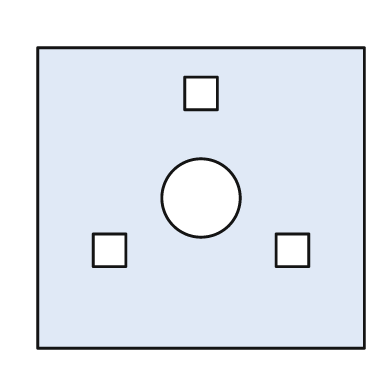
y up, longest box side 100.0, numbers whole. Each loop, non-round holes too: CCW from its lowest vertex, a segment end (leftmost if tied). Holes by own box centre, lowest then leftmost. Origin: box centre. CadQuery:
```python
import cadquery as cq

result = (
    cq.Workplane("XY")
    .moveTo(-50.0, -46.0)
    .lineTo(50.0, -46.0)
    .lineTo(50.0, 46.0)
    .lineTo(-50.0, 46.0)
    .close()
    .moveTo(-33.0, -21.0)
    .lineTo(-23.0, -21.0)
    .lineTo(-23.0, -11.0)
    .lineTo(-33.0, -11.0)
    .close()
    .moveTo(23.0, -21.0)
    .lineTo(33.0, -21.0)
    .lineTo(33.0, -11.0)
    .lineTo(23.0, -11.0)
    .close()
    .moveTo(0.0, 0.0)
    .circle(12.0)
    .moveTo(-5.0, 27.0)
    .lineTo(5.0, 27.0)
    .lineTo(5.0, 37.0)
    .lineTo(-5.0, 37.0)
    .close()
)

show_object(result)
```